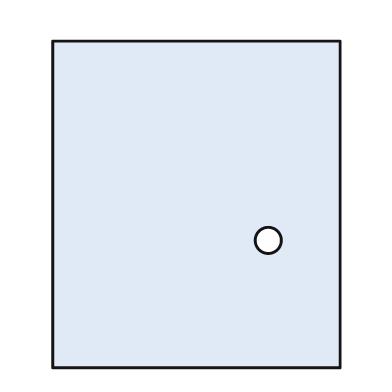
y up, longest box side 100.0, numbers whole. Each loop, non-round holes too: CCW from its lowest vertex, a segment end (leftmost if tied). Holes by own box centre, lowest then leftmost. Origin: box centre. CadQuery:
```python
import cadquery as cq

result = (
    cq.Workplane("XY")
    .moveTo(-44.0, -50.0)
    .lineTo(44.0, -50.0)
    .lineTo(44.0, 50.0)
    .lineTo(-44.0, 50.0)
    .close()
    .moveTo(22.0, -11.0)
    .circle(4.0)
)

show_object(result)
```